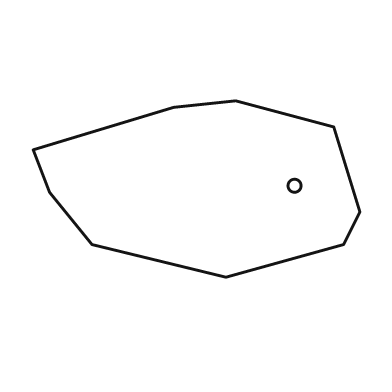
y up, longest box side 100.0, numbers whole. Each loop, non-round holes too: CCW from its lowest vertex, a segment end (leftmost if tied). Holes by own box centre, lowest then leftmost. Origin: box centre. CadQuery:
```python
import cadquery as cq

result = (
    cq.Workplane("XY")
    .moveTo(9.0, -27.0)
    .lineTo(45.0, -17.0)
    .lineTo(50.0, -7.0)
    .lineTo(42.0, 19.0)
    .lineTo(12.0, 27.0)
    .lineTo(-7.0, 25.0)
    .lineTo(-50.0, 12.0)
    .lineTo(-45.0, -1.0)
    .lineTo(-32.0, -17.0)
    .close()
    .moveTo(30.0, 1.0)
    .circle(2.0)
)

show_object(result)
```